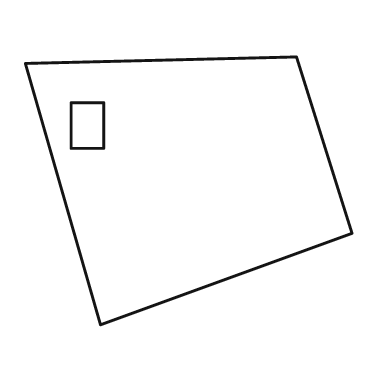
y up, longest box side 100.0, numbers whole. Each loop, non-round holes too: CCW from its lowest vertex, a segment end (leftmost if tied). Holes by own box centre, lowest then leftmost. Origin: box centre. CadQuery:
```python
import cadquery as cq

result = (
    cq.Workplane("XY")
    .moveTo(-27.0, -41.0)
    .lineTo(50.0, -13.0)
    .lineTo(33.0, 41.0)
    .lineTo(-50.0, 39.0)
    .close()
    .moveTo(-36.0, 13.0)
    .lineTo(-26.0, 13.0)
    .lineTo(-26.0, 27.0)
    .lineTo(-36.0, 27.0)
    .close()
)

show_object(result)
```